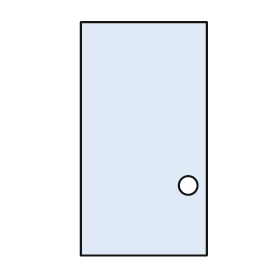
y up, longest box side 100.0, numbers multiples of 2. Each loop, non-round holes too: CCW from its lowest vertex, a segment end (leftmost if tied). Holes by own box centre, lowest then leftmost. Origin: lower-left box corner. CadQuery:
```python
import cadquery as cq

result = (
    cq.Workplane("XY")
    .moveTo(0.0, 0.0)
    .lineTo(54.0, 0.0)
    .lineTo(54.0, 100.0)
    .lineTo(0.0, 100.0)
    .close()
    .moveTo(46.0, 30.0)
    .circle(4.0)
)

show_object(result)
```